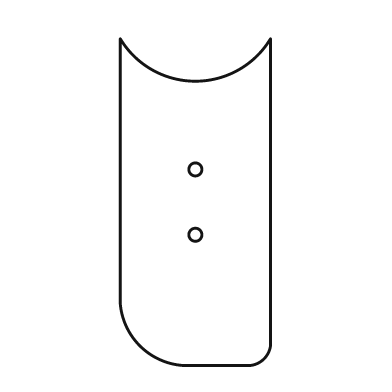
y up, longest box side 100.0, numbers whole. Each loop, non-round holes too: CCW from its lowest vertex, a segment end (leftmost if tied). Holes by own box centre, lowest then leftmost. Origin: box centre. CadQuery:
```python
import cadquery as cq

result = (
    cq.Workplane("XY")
    .moveTo(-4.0, -50.0)
    .lineTo(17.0, -50.0)
    .threePointArc((21.0, -48.0), (23.0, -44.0))
    .lineTo(23.0, 50.0)
    .threePointArc((0.0, 37.0), (-23.0, 50.0))
    .lineTo(-23.0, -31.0)
    .threePointArc((-17.0, -44.0), (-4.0, -50.0))
    .close()
    .moveTo(0.0, -10.0)
    .circle(2.0)
    .moveTo(0.0, 10.0)
    .circle(2.0)
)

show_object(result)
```